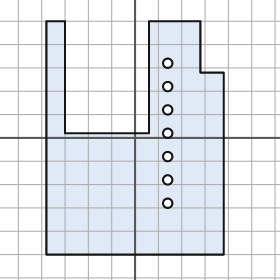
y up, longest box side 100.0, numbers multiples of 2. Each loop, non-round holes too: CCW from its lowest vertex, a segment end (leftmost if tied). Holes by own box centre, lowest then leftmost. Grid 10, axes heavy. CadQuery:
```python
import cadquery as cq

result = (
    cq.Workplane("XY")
    .moveTo(-38.0, -50.0)
    .lineTo(38.0, -50.0)
    .lineTo(38.0, 28.0)
    .lineTo(28.0, 28.0)
    .lineTo(28.0, 50.0)
    .lineTo(6.0, 50.0)
    .lineTo(6.0, 2.0)
    .lineTo(-30.0, 2.0)
    .lineTo(-30.0, 50.0)
    .lineTo(-38.0, 50.0)
    .close()
    .moveTo(14.0, -28.0)
    .circle(2.0)
    .moveTo(14.0, -18.0)
    .circle(2.0)
    .moveTo(14.0, -8.0)
    .circle(2.0)
    .moveTo(14.0, 2.0)
    .circle(2.0)
    .moveTo(14.0, 12.0)
    .circle(2.0)
    .moveTo(14.0, 22.0)
    .circle(2.0)
    .moveTo(14.0, 32.0)
    .circle(2.0)
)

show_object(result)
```